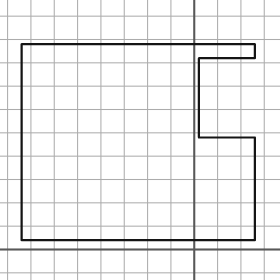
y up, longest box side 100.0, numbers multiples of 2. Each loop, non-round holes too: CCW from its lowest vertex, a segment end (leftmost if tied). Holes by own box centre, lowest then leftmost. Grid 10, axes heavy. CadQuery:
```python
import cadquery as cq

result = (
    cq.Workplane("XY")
    .moveTo(-74.0, 4.0)
    .lineTo(26.0, 4.0)
    .lineTo(26.0, 48.0)
    .lineTo(2.0, 48.0)
    .lineTo(2.0, 82.0)
    .lineTo(26.0, 82.0)
    .lineTo(26.0, 88.0)
    .lineTo(-74.0, 88.0)
    .close()
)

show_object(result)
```